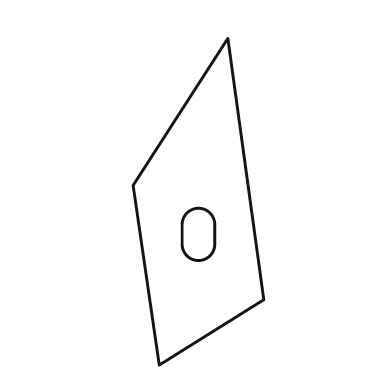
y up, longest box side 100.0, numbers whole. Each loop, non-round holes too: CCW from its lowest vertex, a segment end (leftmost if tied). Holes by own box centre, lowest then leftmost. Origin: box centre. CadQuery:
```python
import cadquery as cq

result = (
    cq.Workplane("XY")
    .moveTo(-12.0, -50.0)
    .lineTo(20.0, -30.0)
    .lineTo(9.0, 50.0)
    .lineTo(-20.0, 5.0)
    .close()
    .moveTo(-5.0, -13.0)
    .threePointArc((0.0, -18.0), (5.0, -13.0))
    .lineTo(5.0, -7.0)
    .threePointArc((0.0, -2.0), (-5.0, -7.0))
    .close()
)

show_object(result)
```